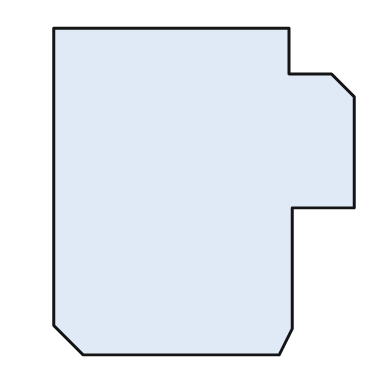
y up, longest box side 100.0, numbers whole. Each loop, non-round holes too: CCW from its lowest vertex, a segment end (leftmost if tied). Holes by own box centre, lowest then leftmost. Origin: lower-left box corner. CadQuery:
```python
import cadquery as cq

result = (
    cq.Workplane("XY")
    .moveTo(9.0, 0.0)
    .lineTo(69.0, 0.0)
    .lineTo(73.0, 8.0)
    .lineTo(73.0, 45.0)
    .lineTo(92.0, 45.0)
    .lineTo(92.0, 79.0)
    .lineTo(85.0, 86.0)
    .lineTo(72.0, 86.0)
    .lineTo(72.0, 100.0)
    .lineTo(0.0, 100.0)
    .lineTo(0.0, 9.0)
    .close()
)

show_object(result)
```